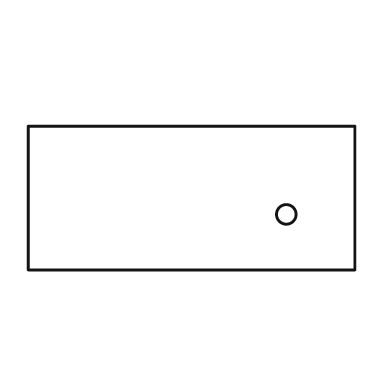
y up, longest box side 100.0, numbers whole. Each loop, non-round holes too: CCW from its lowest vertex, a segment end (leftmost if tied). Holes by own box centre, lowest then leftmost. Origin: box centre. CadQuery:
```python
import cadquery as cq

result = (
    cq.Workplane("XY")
    .moveTo(-50.0, -22.0)
    .lineTo(50.0, -22.0)
    .lineTo(50.0, 22.0)
    .lineTo(-50.0, 22.0)
    .close()
    .moveTo(29.0, -5.0)
    .circle(3.0)
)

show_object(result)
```